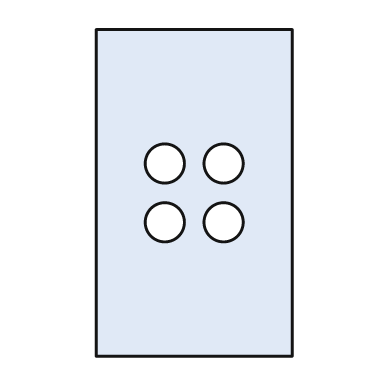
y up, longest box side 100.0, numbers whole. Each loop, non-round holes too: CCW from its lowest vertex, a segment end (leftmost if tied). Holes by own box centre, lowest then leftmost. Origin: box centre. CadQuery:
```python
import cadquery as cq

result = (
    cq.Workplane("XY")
    .moveTo(-30.0, -50.0)
    .lineTo(30.0, -50.0)
    .lineTo(30.0, 50.0)
    .lineTo(-30.0, 50.0)
    .close()
    .moveTo(-9.0, -9.0)
    .circle(6.0)
    .moveTo(9.0, -9.0)
    .circle(6.0)
    .moveTo(-9.0, 9.0)
    .circle(6.0)
    .moveTo(9.0, 9.0)
    .circle(6.0)
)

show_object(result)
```